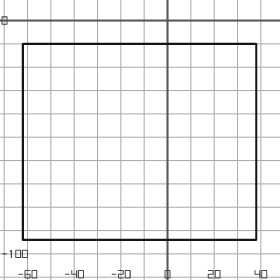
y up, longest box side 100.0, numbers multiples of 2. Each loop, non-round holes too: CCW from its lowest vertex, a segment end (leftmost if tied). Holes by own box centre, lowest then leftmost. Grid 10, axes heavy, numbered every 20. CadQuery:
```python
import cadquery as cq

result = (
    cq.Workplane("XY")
    .moveTo(-62.0, -94.0)
    .lineTo(38.0, -94.0)
    .lineTo(38.0, -10.0)
    .lineTo(-62.0, -10.0)
    .close()
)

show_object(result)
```